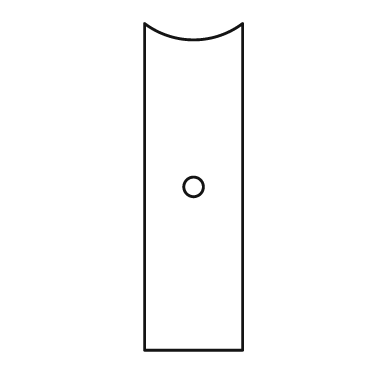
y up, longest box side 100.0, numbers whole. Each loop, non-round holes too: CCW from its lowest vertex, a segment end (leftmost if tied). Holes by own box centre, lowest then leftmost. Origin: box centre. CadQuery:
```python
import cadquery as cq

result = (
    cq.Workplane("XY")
    .moveTo(-15.0, -50.0)
    .lineTo(15.0, -50.0)
    .lineTo(15.0, 50.0)
    .threePointArc((0.0, 45.0), (-15.0, 50.0))
    .close()
    .moveTo(0.0, 0.0)
    .circle(3.0)
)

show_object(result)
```